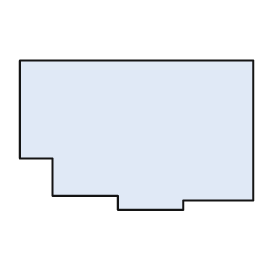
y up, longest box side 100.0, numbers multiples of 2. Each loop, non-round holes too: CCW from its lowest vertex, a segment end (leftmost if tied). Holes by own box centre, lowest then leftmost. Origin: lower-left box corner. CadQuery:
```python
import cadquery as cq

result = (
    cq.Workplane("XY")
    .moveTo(42.0, 0.0)
    .lineTo(70.0, 0.0)
    .lineTo(70.0, 4.0)
    .lineTo(100.0, 4.0)
    .lineTo(100.0, 64.0)
    .lineTo(0.0, 64.0)
    .lineTo(0.0, 22.0)
    .lineTo(14.0, 22.0)
    .lineTo(14.0, 6.0)
    .lineTo(42.0, 6.0)
    .close()
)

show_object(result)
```